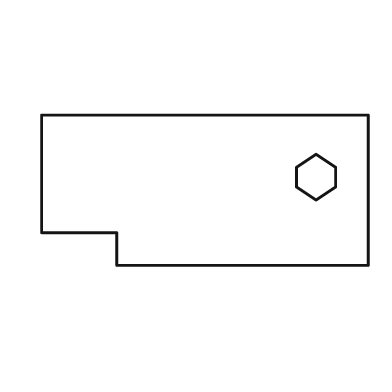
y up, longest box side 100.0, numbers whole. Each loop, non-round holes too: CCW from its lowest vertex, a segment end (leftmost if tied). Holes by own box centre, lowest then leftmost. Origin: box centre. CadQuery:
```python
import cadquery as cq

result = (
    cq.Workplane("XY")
    .moveTo(-27.0, -23.0)
    .lineTo(50.0, -23.0)
    .lineTo(50.0, 23.0)
    .lineTo(-50.0, 23.0)
    .lineTo(-50.0, -13.0)
    .lineTo(-27.0, -13.0)
    .close()
    .moveTo(34.0, -3.0)
    .lineTo(40.0, 1.0)
    .lineTo(40.0, 7.0)
    .lineTo(34.0, 11.0)
    .lineTo(28.0, 7.0)
    .lineTo(28.0, 1.0)
    .close()
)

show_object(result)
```